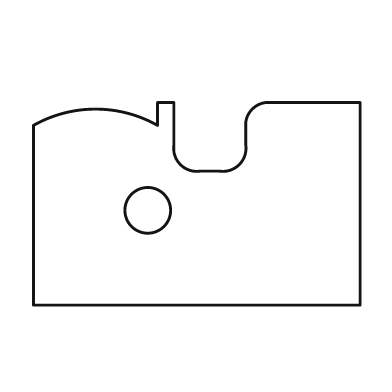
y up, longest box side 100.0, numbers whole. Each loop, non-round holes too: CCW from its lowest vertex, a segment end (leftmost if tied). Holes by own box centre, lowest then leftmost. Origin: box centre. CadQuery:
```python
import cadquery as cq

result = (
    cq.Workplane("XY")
    .moveTo(-50.0, -31.0)
    .lineTo(50.0, -31.0)
    .lineTo(50.0, 31.0)
    .lineTo(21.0, 31.0)
    .threePointArc((17.0, 29.0), (15.0, 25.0))
    .lineTo(15.0, 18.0)
    .threePointArc((13.0, 12.0), (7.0, 10.0))
    .lineTo(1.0, 10.0)
    .threePointArc((-5.0, 12.0), (-7.0, 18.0))
    .lineTo(-7.0, 31.0)
    .lineTo(-12.0, 31.0)
    .lineTo(-12.0, 24.0)
    .threePointArc((-31.0, 29.0), (-50.0, 24.0))
    .close()
    .moveTo(-15.0, -2.0)
    .circle(7.0)
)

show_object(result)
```